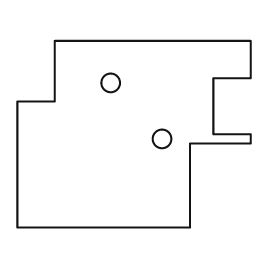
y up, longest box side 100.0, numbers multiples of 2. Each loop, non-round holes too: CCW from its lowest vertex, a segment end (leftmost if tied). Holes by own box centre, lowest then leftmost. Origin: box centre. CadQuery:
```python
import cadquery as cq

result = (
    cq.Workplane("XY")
    .moveTo(-50.0, -40.0)
    .lineTo(24.0, -40.0)
    .lineTo(24.0, -4.0)
    .lineTo(50.0, -4.0)
    .lineTo(50.0, 0.0)
    .lineTo(34.0, 0.0)
    .lineTo(34.0, 24.0)
    .lineTo(50.0, 24.0)
    .lineTo(50.0, 40.0)
    .lineTo(-34.0, 40.0)
    .lineTo(-34.0, 14.0)
    .lineTo(-50.0, 14.0)
    .close()
    .moveTo(12.0, -2.0)
    .circle(4.0)
    .moveTo(-10.0, 22.0)
    .circle(4.0)
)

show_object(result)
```